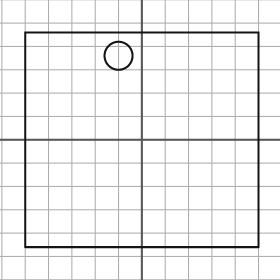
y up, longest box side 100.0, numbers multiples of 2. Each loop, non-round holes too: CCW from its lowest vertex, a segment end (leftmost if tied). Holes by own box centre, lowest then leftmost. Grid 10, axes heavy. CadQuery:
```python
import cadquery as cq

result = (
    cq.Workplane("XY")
    .moveTo(-50.0, -46.0)
    .lineTo(50.0, -46.0)
    .lineTo(50.0, 46.0)
    .lineTo(-50.0, 46.0)
    .close()
    .moveTo(-10.0, 36.0)
    .circle(6.0)
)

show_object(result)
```